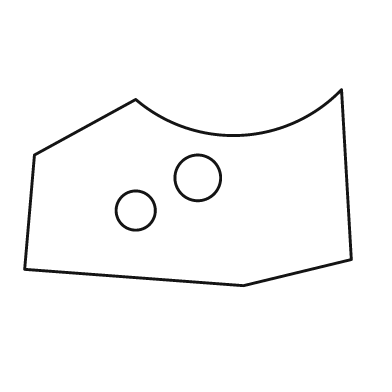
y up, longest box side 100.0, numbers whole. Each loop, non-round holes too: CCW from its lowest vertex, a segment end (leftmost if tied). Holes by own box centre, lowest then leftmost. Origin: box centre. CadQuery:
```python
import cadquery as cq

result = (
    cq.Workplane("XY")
    .moveTo(17.0, -30.0)
    .lineTo(50.0, -22.0)
    .lineTo(47.0, 30.0)
    .threePointArc((16.0, 16.0), (-16.0, 27.0))
    .lineTo(-47.0, 10.0)
    .lineTo(-50.0, -25.0)
    .close()
    .moveTo(-16.0, -7.0)
    .circle(6.0)
    .moveTo(3.0, 3.0)
    .circle(7.0)
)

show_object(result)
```